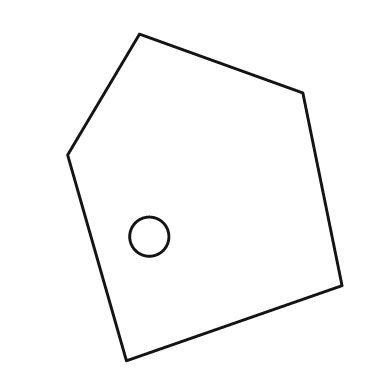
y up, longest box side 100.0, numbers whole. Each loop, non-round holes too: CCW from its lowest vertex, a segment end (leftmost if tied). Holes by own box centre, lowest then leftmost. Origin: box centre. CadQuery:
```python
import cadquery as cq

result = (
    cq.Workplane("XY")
    .moveTo(-24.0, -50.0)
    .lineTo(42.0, -27.0)
    .lineTo(30.0, 32.0)
    .lineTo(-20.0, 50.0)
    .lineTo(-42.0, 13.0)
    .close()
    .moveTo(-17.0, -12.0)
    .circle(6.0)
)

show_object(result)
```